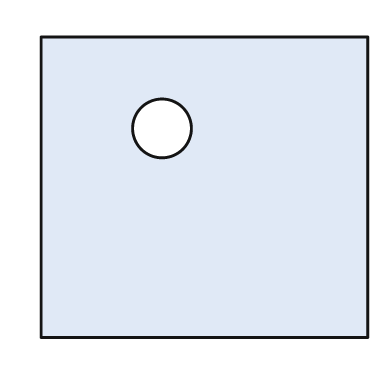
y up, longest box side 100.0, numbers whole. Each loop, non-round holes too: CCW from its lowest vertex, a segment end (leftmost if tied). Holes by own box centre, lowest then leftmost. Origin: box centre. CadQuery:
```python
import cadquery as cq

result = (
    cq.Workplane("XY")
    .moveTo(-50.0, -46.0)
    .lineTo(50.0, -46.0)
    .lineTo(50.0, 46.0)
    .lineTo(-50.0, 46.0)
    .close()
    .moveTo(-13.0, 18.0)
    .circle(9.0)
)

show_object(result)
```